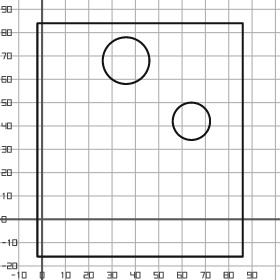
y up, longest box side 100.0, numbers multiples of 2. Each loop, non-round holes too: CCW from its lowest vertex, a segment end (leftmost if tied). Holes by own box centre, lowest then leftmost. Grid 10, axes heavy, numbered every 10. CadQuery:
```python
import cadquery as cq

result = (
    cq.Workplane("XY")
    .moveTo(-2.0, -16.0)
    .lineTo(86.0, -16.0)
    .lineTo(86.0, 84.0)
    .lineTo(-2.0, 84.0)
    .close()
    .moveTo(64.0, 42.0)
    .circle(8.0)
    .moveTo(36.0, 68.0)
    .circle(10.0)
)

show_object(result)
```